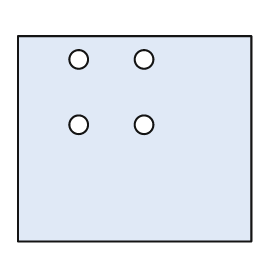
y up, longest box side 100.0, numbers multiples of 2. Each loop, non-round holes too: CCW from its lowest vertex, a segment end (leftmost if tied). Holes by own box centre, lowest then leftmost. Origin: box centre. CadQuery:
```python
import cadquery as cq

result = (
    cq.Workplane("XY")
    .moveTo(-50.0, -44.0)
    .lineTo(50.0, -44.0)
    .lineTo(50.0, 44.0)
    .lineTo(-50.0, 44.0)
    .close()
    .moveTo(-24.0, 6.0)
    .circle(4.0)
    .moveTo(4.0, 6.0)
    .circle(4.0)
    .moveTo(-24.0, 34.0)
    .circle(4.0)
    .moveTo(4.0, 34.0)
    .circle(4.0)
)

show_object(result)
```